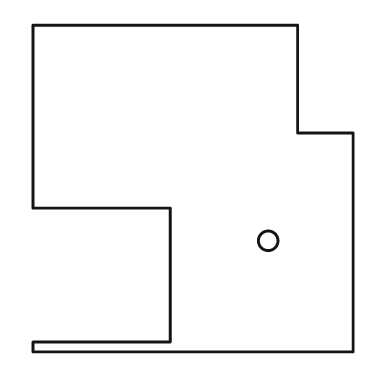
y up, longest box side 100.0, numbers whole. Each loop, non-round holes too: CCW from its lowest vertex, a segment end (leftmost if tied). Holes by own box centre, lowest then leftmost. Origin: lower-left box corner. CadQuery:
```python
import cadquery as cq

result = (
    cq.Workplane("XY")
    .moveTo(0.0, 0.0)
    .lineTo(98.0, 0.0)
    .lineTo(98.0, 67.0)
    .lineTo(81.0, 67.0)
    .lineTo(81.0, 100.0)
    .lineTo(0.0, 100.0)
    .lineTo(0.0, 44.0)
    .lineTo(42.0, 44.0)
    .lineTo(42.0, 3.0)
    .lineTo(0.0, 3.0)
    .close()
    .moveTo(72.0, 34.0)
    .circle(3.0)
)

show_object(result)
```